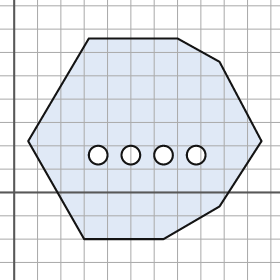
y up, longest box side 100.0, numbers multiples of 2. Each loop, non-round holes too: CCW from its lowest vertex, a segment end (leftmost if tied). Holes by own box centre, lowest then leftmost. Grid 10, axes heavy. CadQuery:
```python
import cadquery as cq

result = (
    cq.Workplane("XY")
    .moveTo(30.0, -20.0)
    .lineTo(64.0, -20.0)
    .lineTo(88.0, -6.0)
    .lineTo(106.0, 22.0)
    .lineTo(88.0, 56.0)
    .lineTo(70.0, 66.0)
    .lineTo(32.0, 66.0)
    .lineTo(6.0, 22.0)
    .close()
    .moveTo(36.0, 16.0)
    .circle(4.0)
    .moveTo(50.0, 16.0)
    .circle(4.0)
    .moveTo(64.0, 16.0)
    .circle(4.0)
    .moveTo(78.0, 16.0)
    .circle(4.0)
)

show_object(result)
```